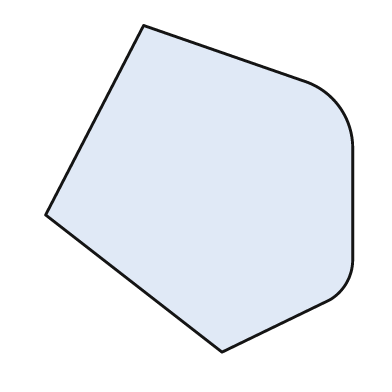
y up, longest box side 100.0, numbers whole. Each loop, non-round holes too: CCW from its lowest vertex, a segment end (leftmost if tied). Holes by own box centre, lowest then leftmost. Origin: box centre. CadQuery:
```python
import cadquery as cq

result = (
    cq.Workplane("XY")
    .moveTo(7.0, -50.0)
    .lineTo(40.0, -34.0)
    .threePointArc((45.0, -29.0), (47.0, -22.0))
    .lineTo(47.0, 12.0)
    .threePointArc((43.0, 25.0), (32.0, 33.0))
    .lineTo(-17.0, 50.0)
    .lineTo(-47.0, -8.0)
    .close()
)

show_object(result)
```